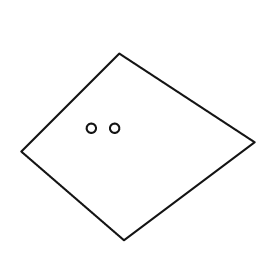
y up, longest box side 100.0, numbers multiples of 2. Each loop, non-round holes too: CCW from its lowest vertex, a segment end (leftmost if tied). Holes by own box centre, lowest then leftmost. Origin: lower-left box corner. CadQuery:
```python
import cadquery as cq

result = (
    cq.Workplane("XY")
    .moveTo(44.0, 0.0)
    .lineTo(100.0, 42.0)
    .lineTo(42.0, 80.0)
    .lineTo(0.0, 38.0)
    .close()
    .moveTo(30.0, 48.0)
    .circle(2.0)
    .moveTo(40.0, 48.0)
    .circle(2.0)
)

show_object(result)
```